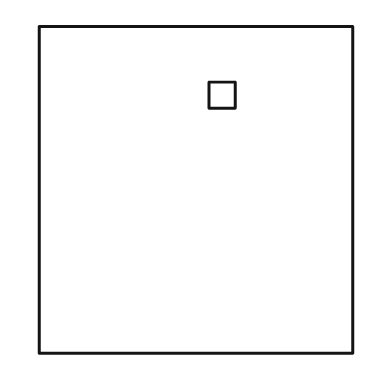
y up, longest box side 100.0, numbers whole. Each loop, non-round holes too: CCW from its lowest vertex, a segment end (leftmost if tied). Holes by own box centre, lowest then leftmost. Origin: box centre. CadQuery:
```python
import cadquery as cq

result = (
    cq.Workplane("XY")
    .moveTo(-48.0, -50.0)
    .lineTo(48.0, -50.0)
    .lineTo(48.0, 50.0)
    .lineTo(-48.0, 50.0)
    .close()
    .moveTo(4.0, 25.0)
    .lineTo(12.0, 25.0)
    .lineTo(12.0, 33.0)
    .lineTo(4.0, 33.0)
    .close()
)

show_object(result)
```